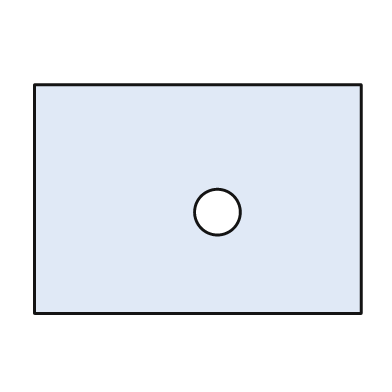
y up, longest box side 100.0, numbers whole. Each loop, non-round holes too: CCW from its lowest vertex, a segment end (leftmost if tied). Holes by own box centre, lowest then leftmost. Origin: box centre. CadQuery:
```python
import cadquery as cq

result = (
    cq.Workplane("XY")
    .moveTo(-50.0, -35.0)
    .lineTo(50.0, -35.0)
    .lineTo(50.0, 35.0)
    .lineTo(-50.0, 35.0)
    .close()
    .moveTo(6.0, -4.0)
    .circle(7.0)
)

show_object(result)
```